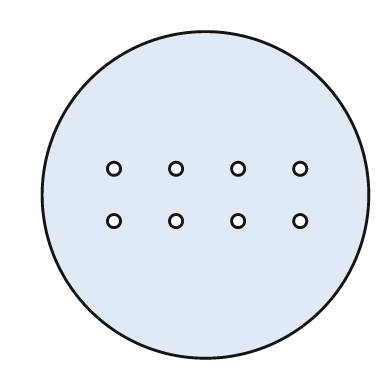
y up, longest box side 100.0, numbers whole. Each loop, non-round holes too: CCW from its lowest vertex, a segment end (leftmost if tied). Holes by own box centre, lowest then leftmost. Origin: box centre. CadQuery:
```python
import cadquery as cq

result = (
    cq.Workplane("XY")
    .moveTo(0.0, 0.0)
    .circle(50.0)
    .moveTo(-28.0, -8.0)
    .circle(2.0)
    .moveTo(-9.0, -8.0)
    .circle(2.0)
    .moveTo(10.0, -8.0)
    .circle(2.0)
    .moveTo(29.0, -8.0)
    .circle(2.0)
    .moveTo(-28.0, 8.0)
    .circle(2.0)
    .moveTo(-9.0, 8.0)
    .circle(2.0)
    .moveTo(10.0, 8.0)
    .circle(2.0)
    .moveTo(29.0, 8.0)
    .circle(2.0)
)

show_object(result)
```